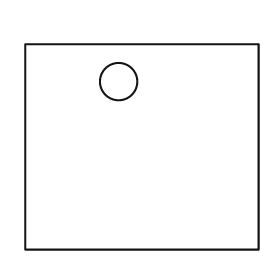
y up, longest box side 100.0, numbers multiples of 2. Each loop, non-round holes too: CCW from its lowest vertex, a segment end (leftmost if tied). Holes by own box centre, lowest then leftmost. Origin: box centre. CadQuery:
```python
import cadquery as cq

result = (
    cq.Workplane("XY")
    .moveTo(-50.0, -44.0)
    .lineTo(50.0, -44.0)
    .lineTo(50.0, 44.0)
    .lineTo(-50.0, 44.0)
    .close()
    .moveTo(-10.0, 28.0)
    .circle(8.0)
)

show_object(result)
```